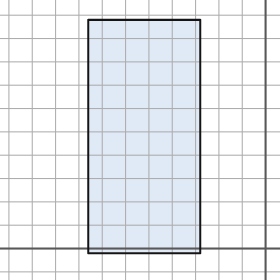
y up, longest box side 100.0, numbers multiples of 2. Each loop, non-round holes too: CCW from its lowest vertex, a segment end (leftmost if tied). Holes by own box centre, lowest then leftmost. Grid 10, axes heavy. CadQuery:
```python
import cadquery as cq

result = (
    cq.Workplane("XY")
    .moveTo(-76.0, -2.0)
    .lineTo(-28.0, -2.0)
    .lineTo(-28.0, 98.0)
    .lineTo(-76.0, 98.0)
    .close()
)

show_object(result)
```